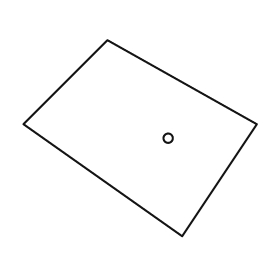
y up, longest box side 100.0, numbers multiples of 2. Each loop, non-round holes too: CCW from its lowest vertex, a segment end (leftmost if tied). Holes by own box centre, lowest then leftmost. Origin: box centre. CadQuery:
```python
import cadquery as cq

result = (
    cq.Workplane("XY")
    .moveTo(18.0, -42.0)
    .lineTo(50.0, 6.0)
    .lineTo(-14.0, 42.0)
    .lineTo(-50.0, 6.0)
    .close()
    .moveTo(12.0, 0.0)
    .circle(2.0)
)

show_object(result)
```